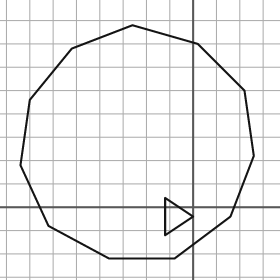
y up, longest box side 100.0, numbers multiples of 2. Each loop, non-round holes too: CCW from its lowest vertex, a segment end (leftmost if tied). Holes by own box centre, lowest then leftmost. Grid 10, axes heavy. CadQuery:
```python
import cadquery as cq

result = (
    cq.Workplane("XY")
    .moveTo(-36.0, -22.0)
    .lineTo(-8.0, -22.0)
    .lineTo(16.0, -4.0)
    .lineTo(26.0, 22.0)
    .lineTo(22.0, 50.0)
    .lineTo(2.0, 70.0)
    .lineTo(-26.0, 78.0)
    .lineTo(-52.0, 68.0)
    .lineTo(-70.0, 46.0)
    .lineTo(-74.0, 18.0)
    .lineTo(-62.0, -8.0)
    .close()
    .moveTo(-12.0, -12.0)
    .lineTo(0.0, -4.0)
    .lineTo(-12.0, 4.0)
    .close()
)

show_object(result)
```